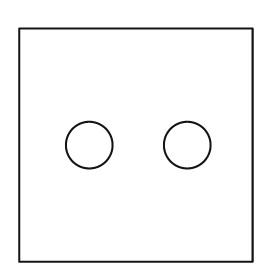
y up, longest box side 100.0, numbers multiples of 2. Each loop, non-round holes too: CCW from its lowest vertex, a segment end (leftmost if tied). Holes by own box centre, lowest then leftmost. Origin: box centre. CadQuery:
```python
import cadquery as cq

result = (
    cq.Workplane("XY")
    .moveTo(-50.0, -50.0)
    .lineTo(50.0, -50.0)
    .lineTo(50.0, 50.0)
    .lineTo(-50.0, 50.0)
    .close()
    .moveTo(-20.0, 0.0)
    .circle(10.0)
    .moveTo(22.0, 0.0)
    .circle(10.0)
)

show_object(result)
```